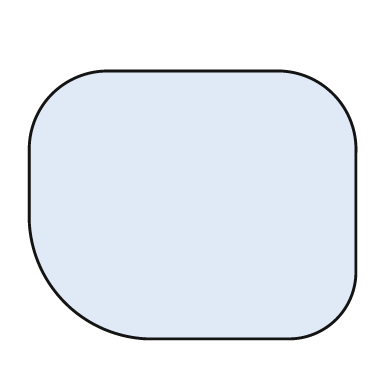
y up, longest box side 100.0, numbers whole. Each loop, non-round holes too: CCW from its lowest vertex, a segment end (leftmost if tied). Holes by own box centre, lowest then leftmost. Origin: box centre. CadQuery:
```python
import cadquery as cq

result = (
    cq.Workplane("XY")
    .moveTo(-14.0, -41.0)
    .lineTo(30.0, -41.0)
    .threePointArc((44.0, -35.0), (50.0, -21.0))
    .lineTo(50.0, 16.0)
    .threePointArc((43.0, 34.0), (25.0, 41.0))
    .lineTo(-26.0, 41.0)
    .threePointArc((-43.0, 34.0), (-50.0, 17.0))
    .lineTo(-50.0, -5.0)
    .threePointArc((-39.0, -30.0), (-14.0, -41.0))
    .close()
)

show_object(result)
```